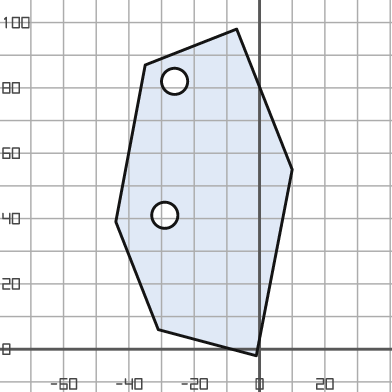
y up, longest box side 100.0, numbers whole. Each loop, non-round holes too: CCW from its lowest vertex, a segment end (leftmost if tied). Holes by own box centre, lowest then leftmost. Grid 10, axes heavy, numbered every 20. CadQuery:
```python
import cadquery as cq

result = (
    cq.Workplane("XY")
    .moveTo(-1.0, -2.0)
    .lineTo(10.0, 55.0)
    .lineTo(-7.0, 98.0)
    .lineTo(-35.0, 87.0)
    .lineTo(-44.0, 39.0)
    .lineTo(-31.0, 6.0)
    .close()
    .moveTo(-29.0, 41.0)
    .circle(4.0)
    .moveTo(-26.0, 82.0)
    .circle(4.0)
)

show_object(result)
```